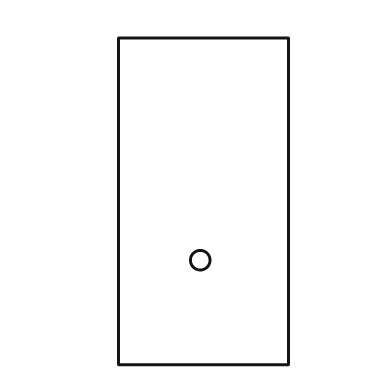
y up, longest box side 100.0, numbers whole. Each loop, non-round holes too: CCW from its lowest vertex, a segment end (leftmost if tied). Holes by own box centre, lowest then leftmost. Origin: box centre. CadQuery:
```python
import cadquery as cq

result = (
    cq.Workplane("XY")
    .moveTo(-26.0, -50.0)
    .lineTo(26.0, -50.0)
    .lineTo(26.0, 50.0)
    .lineTo(-26.0, 50.0)
    .close()
    .moveTo(-1.0, -18.0)
    .circle(3.0)
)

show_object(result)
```